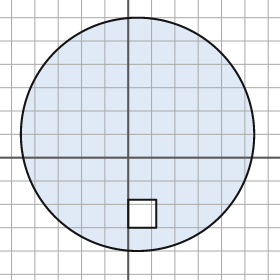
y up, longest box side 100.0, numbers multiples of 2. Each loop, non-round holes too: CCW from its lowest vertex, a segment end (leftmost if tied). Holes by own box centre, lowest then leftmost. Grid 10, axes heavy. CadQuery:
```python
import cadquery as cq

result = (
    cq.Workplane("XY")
    .moveTo(4.0, 10.0)
    .circle(50.0)
    .moveTo(0.0, -30.0)
    .lineTo(12.0, -30.0)
    .lineTo(12.0, -18.0)
    .lineTo(0.0, -18.0)
    .close()
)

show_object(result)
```